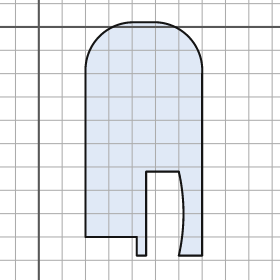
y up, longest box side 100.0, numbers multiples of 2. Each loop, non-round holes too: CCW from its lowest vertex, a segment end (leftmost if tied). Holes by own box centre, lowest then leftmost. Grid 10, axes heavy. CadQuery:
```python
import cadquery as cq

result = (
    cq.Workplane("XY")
    .moveTo(42.0, -98.0)
    .lineTo(46.0, -98.0)
    .lineTo(46.0, -62.0)
    .lineTo(60.0, -62.0)
    .threePointArc((62.0, -80.0), (60.0, -98.0))
    .lineTo(70.0, -98.0)
    .lineTo(70.0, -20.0)
    .threePointArc((64.0, -4.0), (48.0, 2.0))
    .lineTo(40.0, 2.0)
    .threePointArc((26.0, -4.0), (20.0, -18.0))
    .lineTo(20.0, -90.0)
    .lineTo(42.0, -90.0)
    .close()
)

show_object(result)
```